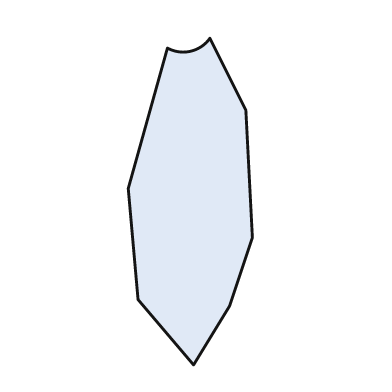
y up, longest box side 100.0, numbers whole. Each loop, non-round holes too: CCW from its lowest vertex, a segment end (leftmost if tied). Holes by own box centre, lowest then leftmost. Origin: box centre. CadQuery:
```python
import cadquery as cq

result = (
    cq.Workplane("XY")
    .moveTo(1.0, -50.0)
    .lineTo(12.0, -32.0)
    .lineTo(19.0, -11.0)
    .lineTo(17.0, 28.0)
    .lineTo(6.0, 50.0)
    .threePointArc((0.0, 46.0), (-7.0, 47.0))
    .lineTo(-19.0, 4.0)
    .lineTo(-16.0, -30.0)
    .close()
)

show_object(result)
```